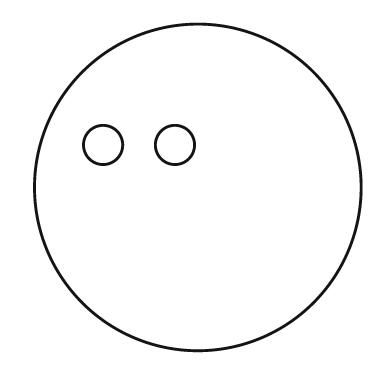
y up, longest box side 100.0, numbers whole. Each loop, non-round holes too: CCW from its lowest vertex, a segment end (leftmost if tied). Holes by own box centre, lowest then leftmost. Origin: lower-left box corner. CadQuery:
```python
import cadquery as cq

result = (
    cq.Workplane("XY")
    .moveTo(50.0, 50.0)
    .circle(50.0)
    .moveTo(21.0, 63.0)
    .circle(6.0)
    .moveTo(43.0, 63.0)
    .circle(6.0)
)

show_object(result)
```